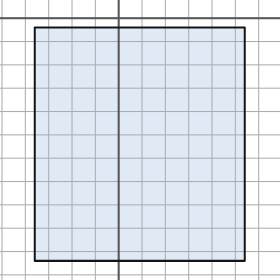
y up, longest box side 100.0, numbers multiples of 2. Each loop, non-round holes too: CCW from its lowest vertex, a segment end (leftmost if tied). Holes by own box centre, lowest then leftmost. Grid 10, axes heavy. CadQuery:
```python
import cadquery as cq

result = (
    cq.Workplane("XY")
    .moveTo(-36.0, -104.0)
    .lineTo(54.0, -104.0)
    .lineTo(54.0, -4.0)
    .lineTo(-36.0, -4.0)
    .close()
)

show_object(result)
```